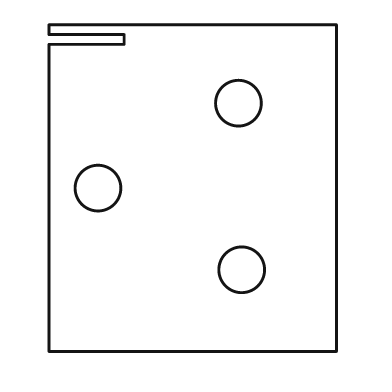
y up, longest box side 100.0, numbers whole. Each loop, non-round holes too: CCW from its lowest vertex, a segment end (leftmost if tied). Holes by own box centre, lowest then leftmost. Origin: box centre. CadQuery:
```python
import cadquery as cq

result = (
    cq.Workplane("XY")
    .moveTo(-44.0, -50.0)
    .lineTo(44.0, -50.0)
    .lineTo(44.0, 50.0)
    .lineTo(-44.0, 50.0)
    .lineTo(-44.0, 47.0)
    .lineTo(-21.0, 47.0)
    .lineTo(-21.0, 44.0)
    .lineTo(-44.0, 44.0)
    .close()
    .moveTo(15.0, -25.0)
    .circle(7.0)
    .moveTo(-29.0, 0.0)
    .circle(7.0)
    .moveTo(14.0, 26.0)
    .circle(7.0)
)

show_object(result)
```